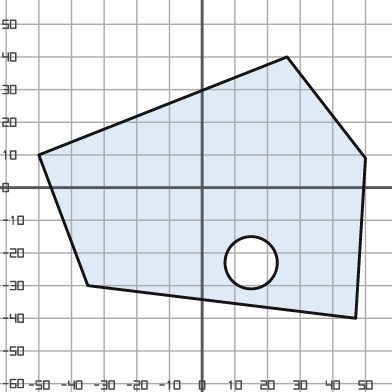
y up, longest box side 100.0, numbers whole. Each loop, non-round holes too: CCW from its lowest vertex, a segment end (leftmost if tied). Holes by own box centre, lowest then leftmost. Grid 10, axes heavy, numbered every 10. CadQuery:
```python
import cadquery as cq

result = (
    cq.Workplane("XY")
    .moveTo(47.0, -40.0)
    .lineTo(50.0, 9.0)
    .lineTo(26.0, 40.0)
    .lineTo(-50.0, 10.0)
    .lineTo(-35.0, -30.0)
    .close()
    .moveTo(15.0, -23.0)
    .circle(8.0)
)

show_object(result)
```